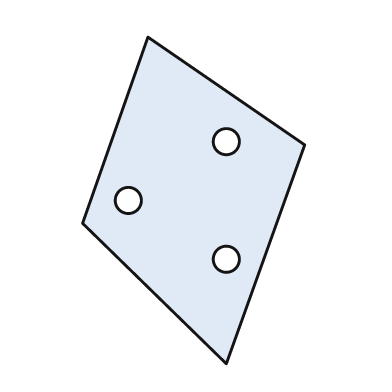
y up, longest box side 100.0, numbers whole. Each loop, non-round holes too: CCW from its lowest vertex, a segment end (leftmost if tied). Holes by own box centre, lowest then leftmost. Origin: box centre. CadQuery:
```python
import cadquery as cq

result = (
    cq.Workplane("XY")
    .moveTo(10.0, -50.0)
    .lineTo(34.0, 17.0)
    .lineTo(-14.0, 50.0)
    .lineTo(-34.0, -7.0)
    .close()
    .moveTo(10.0, -18.0)
    .circle(4.0)
    .moveTo(-20.0, 0.0)
    .circle(4.0)
    .moveTo(10.0, 18.0)
    .circle(4.0)
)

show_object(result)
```